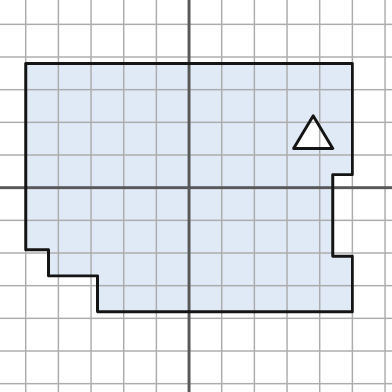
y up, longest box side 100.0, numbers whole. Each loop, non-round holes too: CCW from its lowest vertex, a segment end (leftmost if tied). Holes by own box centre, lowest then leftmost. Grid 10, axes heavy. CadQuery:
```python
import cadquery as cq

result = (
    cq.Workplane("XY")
    .moveTo(-28.0, -38.0)
    .lineTo(50.0, -38.0)
    .lineTo(50.0, -21.0)
    .lineTo(44.0, -21.0)
    .lineTo(44.0, 4.0)
    .lineTo(50.0, 4.0)
    .lineTo(50.0, 38.0)
    .lineTo(-50.0, 38.0)
    .lineTo(-50.0, -19.0)
    .lineTo(-43.0, -19.0)
    .lineTo(-43.0, -27.0)
    .lineTo(-28.0, -27.0)
    .close()
    .moveTo(32.0, 12.0)
    .lineTo(44.0, 12.0)
    .lineTo(38.0, 22.0)
    .close()
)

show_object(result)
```